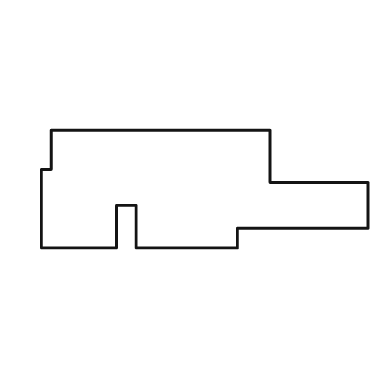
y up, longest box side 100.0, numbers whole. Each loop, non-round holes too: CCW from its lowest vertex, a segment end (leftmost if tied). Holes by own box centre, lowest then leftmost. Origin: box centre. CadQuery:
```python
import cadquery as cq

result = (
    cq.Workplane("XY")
    .moveTo(-50.0, -18.0)
    .lineTo(-27.0, -18.0)
    .lineTo(-27.0, -5.0)
    .lineTo(-21.0, -5.0)
    .lineTo(-21.0, -18.0)
    .lineTo(10.0, -18.0)
    .lineTo(10.0, -12.0)
    .lineTo(50.0, -12.0)
    .lineTo(50.0, 2.0)
    .lineTo(20.0, 2.0)
    .lineTo(20.0, 18.0)
    .lineTo(-47.0, 18.0)
    .lineTo(-47.0, 6.0)
    .lineTo(-50.0, 6.0)
    .close()
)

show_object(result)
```